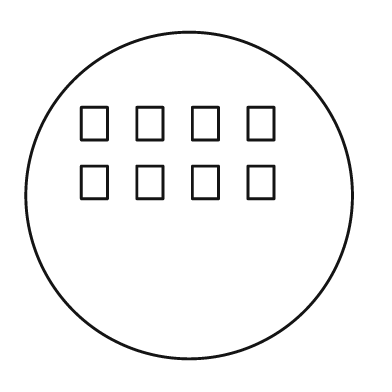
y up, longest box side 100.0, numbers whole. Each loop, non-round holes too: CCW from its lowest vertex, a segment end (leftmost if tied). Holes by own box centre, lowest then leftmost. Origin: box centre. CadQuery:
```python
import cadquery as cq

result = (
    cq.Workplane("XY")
    .moveTo(0.0, 0.0)
    .circle(50.0)
    .moveTo(-33.0, -1.0)
    .lineTo(-25.0, -1.0)
    .lineTo(-25.0, 9.0)
    .lineTo(-33.0, 9.0)
    .close()
    .moveTo(-16.0, -1.0)
    .lineTo(-8.0, -1.0)
    .lineTo(-8.0, 9.0)
    .lineTo(-16.0, 9.0)
    .close()
    .moveTo(1.0, -1.0)
    .lineTo(9.0, -1.0)
    .lineTo(9.0, 9.0)
    .lineTo(1.0, 9.0)
    .close()
    .moveTo(18.0, -1.0)
    .lineTo(26.0, -1.0)
    .lineTo(26.0, 9.0)
    .lineTo(18.0, 9.0)
    .close()
    .moveTo(-33.0, 17.0)
    .lineTo(-25.0, 17.0)
    .lineTo(-25.0, 27.0)
    .lineTo(-33.0, 27.0)
    .close()
    .moveTo(-16.0, 17.0)
    .lineTo(-8.0, 17.0)
    .lineTo(-8.0, 27.0)
    .lineTo(-16.0, 27.0)
    .close()
    .moveTo(1.0, 17.0)
    .lineTo(9.0, 17.0)
    .lineTo(9.0, 27.0)
    .lineTo(1.0, 27.0)
    .close()
    .moveTo(18.0, 17.0)
    .lineTo(26.0, 17.0)
    .lineTo(26.0, 27.0)
    .lineTo(18.0, 27.0)
    .close()
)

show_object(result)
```